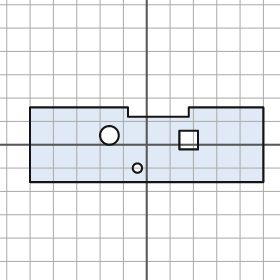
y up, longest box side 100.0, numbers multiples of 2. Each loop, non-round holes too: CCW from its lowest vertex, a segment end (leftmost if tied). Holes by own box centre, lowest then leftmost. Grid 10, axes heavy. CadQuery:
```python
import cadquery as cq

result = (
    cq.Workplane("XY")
    .moveTo(-50.0, -16.0)
    .lineTo(50.0, -16.0)
    .lineTo(50.0, 16.0)
    .lineTo(18.0, 16.0)
    .lineTo(18.0, 12.0)
    .lineTo(-8.0, 12.0)
    .lineTo(-8.0, 16.0)
    .lineTo(-50.0, 16.0)
    .close()
    .moveTo(-4.0, -10.0)
    .circle(2.0)
    .moveTo(14.0, -2.0)
    .lineTo(22.0, -2.0)
    .lineTo(22.0, 6.0)
    .lineTo(14.0, 6.0)
    .close()
    .moveTo(-16.0, 4.0)
    .circle(4.0)
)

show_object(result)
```